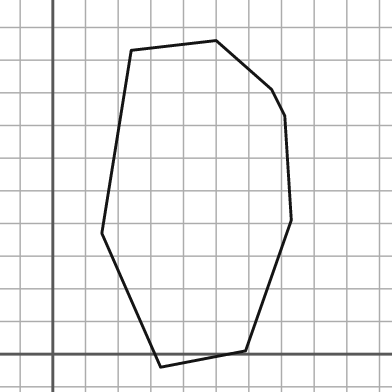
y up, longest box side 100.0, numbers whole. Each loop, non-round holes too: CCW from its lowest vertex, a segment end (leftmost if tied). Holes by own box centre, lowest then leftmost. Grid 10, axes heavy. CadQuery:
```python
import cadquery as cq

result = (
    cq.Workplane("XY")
    .moveTo(33.0, -4.0)
    .lineTo(59.0, 1.0)
    .lineTo(73.0, 41.0)
    .lineTo(71.0, 73.0)
    .lineTo(67.0, 81.0)
    .lineTo(50.0, 96.0)
    .lineTo(24.0, 93.0)
    .lineTo(15.0, 37.0)
    .close()
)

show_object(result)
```